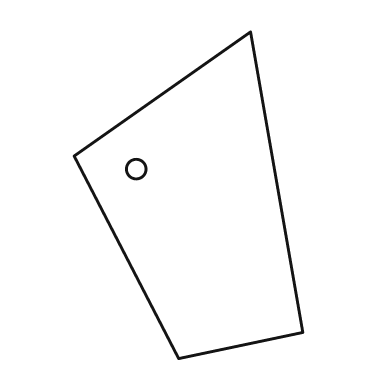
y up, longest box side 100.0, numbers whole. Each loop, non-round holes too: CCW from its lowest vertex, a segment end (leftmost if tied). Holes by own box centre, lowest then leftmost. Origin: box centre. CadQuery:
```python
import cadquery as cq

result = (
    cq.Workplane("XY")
    .moveTo(-3.0, -50.0)
    .lineTo(35.0, -42.0)
    .lineTo(19.0, 50.0)
    .lineTo(-35.0, 12.0)
    .close()
    .moveTo(-16.0, 8.0)
    .circle(3.0)
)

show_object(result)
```